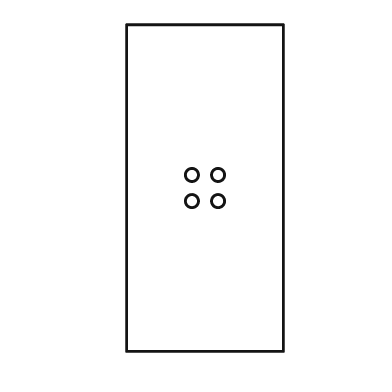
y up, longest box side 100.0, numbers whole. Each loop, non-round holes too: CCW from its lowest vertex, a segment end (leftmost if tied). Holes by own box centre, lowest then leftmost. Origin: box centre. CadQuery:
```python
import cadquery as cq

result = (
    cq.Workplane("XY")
    .moveTo(-24.0, -50.0)
    .lineTo(24.0, -50.0)
    .lineTo(24.0, 50.0)
    .lineTo(-24.0, 50.0)
    .close()
    .moveTo(-4.0, -4.0)
    .circle(2.0)
    .moveTo(4.0, -4.0)
    .circle(2.0)
    .moveTo(-4.0, 4.0)
    .circle(2.0)
    .moveTo(4.0, 4.0)
    .circle(2.0)
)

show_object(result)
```